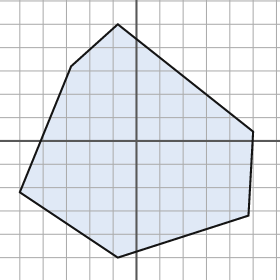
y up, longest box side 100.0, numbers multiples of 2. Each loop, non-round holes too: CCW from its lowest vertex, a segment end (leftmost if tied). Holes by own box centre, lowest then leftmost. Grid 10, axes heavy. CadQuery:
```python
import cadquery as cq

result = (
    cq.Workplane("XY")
    .moveTo(-8.0, -50.0)
    .lineTo(48.0, -32.0)
    .lineTo(50.0, 4.0)
    .lineTo(-8.0, 50.0)
    .lineTo(-28.0, 32.0)
    .lineTo(-50.0, -22.0)
    .close()
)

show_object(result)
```